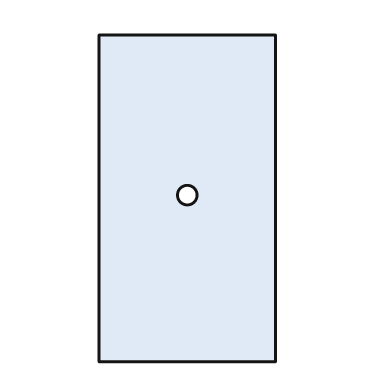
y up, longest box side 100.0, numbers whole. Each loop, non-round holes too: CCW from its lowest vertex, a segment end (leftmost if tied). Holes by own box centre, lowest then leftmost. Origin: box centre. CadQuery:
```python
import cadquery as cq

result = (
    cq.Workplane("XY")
    .moveTo(-27.0, -50.0)
    .lineTo(27.0, -50.0)
    .lineTo(27.0, 50.0)
    .lineTo(-27.0, 50.0)
    .close()
    .moveTo(0.0, 1.0)
    .circle(3.0)
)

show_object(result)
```